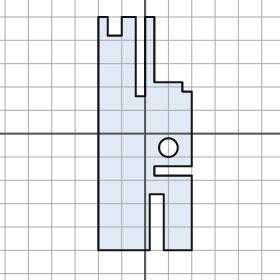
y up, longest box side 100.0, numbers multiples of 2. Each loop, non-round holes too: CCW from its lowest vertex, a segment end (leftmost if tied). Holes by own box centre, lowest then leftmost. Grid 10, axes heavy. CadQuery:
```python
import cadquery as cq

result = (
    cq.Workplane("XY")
    .moveTo(-20.0, -50.0)
    .lineTo(2.0, -50.0)
    .lineTo(2.0, -26.0)
    .lineTo(8.0, -26.0)
    .lineTo(8.0, -50.0)
    .lineTo(20.0, -50.0)
    .lineTo(20.0, -18.0)
    .lineTo(4.0, -18.0)
    .lineTo(4.0, -14.0)
    .lineTo(20.0, -14.0)
    .lineTo(20.0, 18.0)
    .lineTo(16.0, 18.0)
    .lineTo(16.0, 22.0)
    .lineTo(4.0, 22.0)
    .lineTo(4.0, 50.0)
    .lineTo(0.0, 50.0)
    .lineTo(0.0, 16.0)
    .lineTo(-4.0, 16.0)
    .lineTo(-4.0, 50.0)
    .lineTo(-10.0, 50.0)
    .lineTo(-10.0, 42.0)
    .lineTo(-16.0, 42.0)
    .lineTo(-16.0, 50.0)
    .lineTo(-20.0, 50.0)
    .close()
    .moveTo(10.0, -6.0)
    .circle(4.0)
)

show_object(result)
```